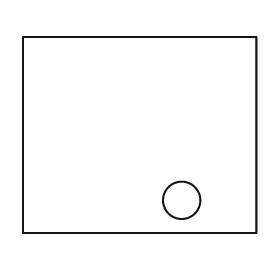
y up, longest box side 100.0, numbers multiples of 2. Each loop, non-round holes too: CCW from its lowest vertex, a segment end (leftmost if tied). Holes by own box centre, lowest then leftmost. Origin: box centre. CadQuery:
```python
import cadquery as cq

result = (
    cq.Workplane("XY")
    .moveTo(-50.0, -42.0)
    .lineTo(50.0, -42.0)
    .lineTo(50.0, 42.0)
    .lineTo(-50.0, 42.0)
    .close()
    .moveTo(18.0, -28.0)
    .circle(8.0)
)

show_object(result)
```